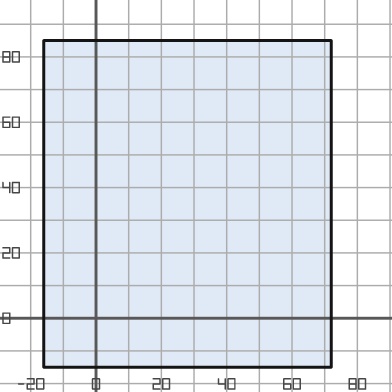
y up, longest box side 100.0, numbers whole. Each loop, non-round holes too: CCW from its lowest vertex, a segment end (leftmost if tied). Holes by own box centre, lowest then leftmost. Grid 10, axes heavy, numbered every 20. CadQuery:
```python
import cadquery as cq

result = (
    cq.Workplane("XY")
    .moveTo(-16.0, -15.0)
    .lineTo(72.0, -15.0)
    .lineTo(72.0, 85.0)
    .lineTo(-16.0, 85.0)
    .close()
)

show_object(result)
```